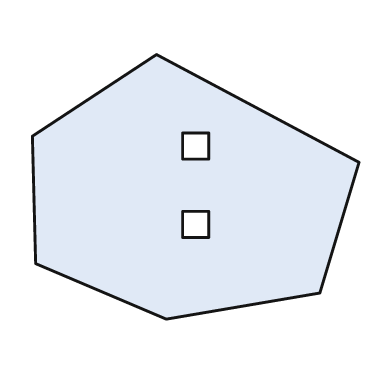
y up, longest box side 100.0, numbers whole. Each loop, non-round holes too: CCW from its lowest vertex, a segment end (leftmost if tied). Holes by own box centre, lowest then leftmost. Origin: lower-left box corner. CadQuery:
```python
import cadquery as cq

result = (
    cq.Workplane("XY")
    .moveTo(41.0, 0.0)
    .lineTo(88.0, 8.0)
    .lineTo(100.0, 48.0)
    .lineTo(38.0, 81.0)
    .lineTo(0.0, 56.0)
    .lineTo(1.0, 17.0)
    .close()
    .moveTo(46.0, 25.0)
    .lineTo(54.0, 25.0)
    .lineTo(54.0, 33.0)
    .lineTo(46.0, 33.0)
    .close()
    .moveTo(46.0, 49.0)
    .lineTo(54.0, 49.0)
    .lineTo(54.0, 57.0)
    .lineTo(46.0, 57.0)
    .close()
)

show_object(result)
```